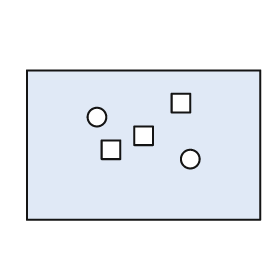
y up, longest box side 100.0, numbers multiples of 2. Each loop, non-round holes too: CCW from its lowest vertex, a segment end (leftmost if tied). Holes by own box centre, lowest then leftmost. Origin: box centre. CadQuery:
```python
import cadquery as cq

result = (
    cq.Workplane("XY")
    .moveTo(-50.0, -32.0)
    .lineTo(50.0, -32.0)
    .lineTo(50.0, 32.0)
    .lineTo(-50.0, 32.0)
    .close()
    .moveTo(20.0, -6.0)
    .circle(4.0)
    .moveTo(-18.0, -6.0)
    .lineTo(-10.0, -6.0)
    .lineTo(-10.0, 2.0)
    .lineTo(-18.0, 2.0)
    .close()
    .moveTo(-4.0, 0.0)
    .lineTo(4.0, 0.0)
    .lineTo(4.0, 8.0)
    .lineTo(-4.0, 8.0)
    .close()
    .moveTo(-20.0, 12.0)
    .circle(4.0)
    .moveTo(12.0, 14.0)
    .lineTo(20.0, 14.0)
    .lineTo(20.0, 22.0)
    .lineTo(12.0, 22.0)
    .close()
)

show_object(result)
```